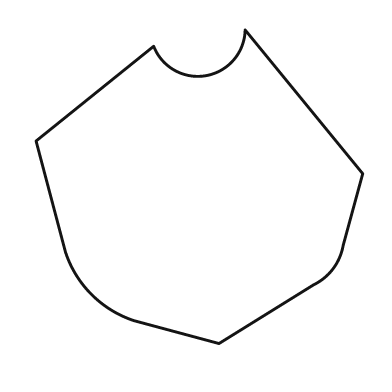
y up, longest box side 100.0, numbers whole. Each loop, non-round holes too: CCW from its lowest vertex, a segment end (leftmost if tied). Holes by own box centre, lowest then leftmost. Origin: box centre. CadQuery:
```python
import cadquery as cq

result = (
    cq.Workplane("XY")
    .moveTo(6.0, -48.0)
    .lineTo(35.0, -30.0)
    .threePointArc((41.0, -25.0), (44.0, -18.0))
    .lineTo(50.0, 4.0)
    .lineTo(14.0, 48.0)
    .threePointArc((2.0, 34.0), (-14.0, 43.0))
    .lineTo(-50.0, 14.0)
    .lineTo(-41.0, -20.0)
    .threePointArc((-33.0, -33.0), (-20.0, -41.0))
    .close()
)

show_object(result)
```